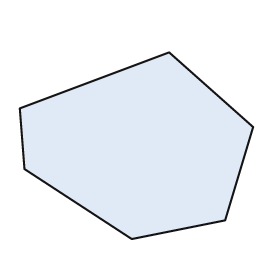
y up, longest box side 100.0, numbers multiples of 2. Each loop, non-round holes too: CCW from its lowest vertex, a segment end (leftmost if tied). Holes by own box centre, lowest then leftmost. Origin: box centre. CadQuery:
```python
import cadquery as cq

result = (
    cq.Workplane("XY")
    .moveTo(-2.0, -40.0)
    .lineTo(38.0, -32.0)
    .lineTo(50.0, 8.0)
    .lineTo(14.0, 40.0)
    .lineTo(-50.0, 16.0)
    .lineTo(-48.0, -10.0)
    .close()
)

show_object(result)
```